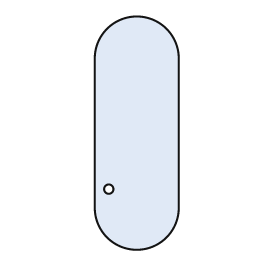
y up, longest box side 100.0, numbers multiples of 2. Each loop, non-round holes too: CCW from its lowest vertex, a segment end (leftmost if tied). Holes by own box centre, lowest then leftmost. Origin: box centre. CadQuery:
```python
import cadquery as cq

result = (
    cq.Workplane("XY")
    .moveTo(-18.0, -32.0)
    .threePointArc((0.0, -50.0), (18.0, -32.0))
    .lineTo(18.0, 32.0)
    .threePointArc((0.0, 50.0), (-18.0, 32.0))
    .close()
    .moveTo(-12.0, -24.0)
    .circle(2.0)
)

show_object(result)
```